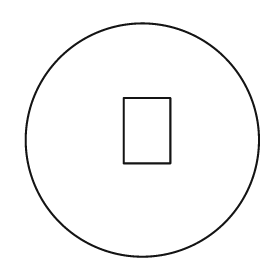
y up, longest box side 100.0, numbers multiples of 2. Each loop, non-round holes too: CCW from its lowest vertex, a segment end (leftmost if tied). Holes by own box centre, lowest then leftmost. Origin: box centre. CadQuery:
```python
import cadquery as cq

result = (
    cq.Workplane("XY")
    .moveTo(0.0, 0.0)
    .circle(50.0)
    .moveTo(-8.0, -10.0)
    .lineTo(12.0, -10.0)
    .lineTo(12.0, 18.0)
    .lineTo(-8.0, 18.0)
    .close()
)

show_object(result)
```